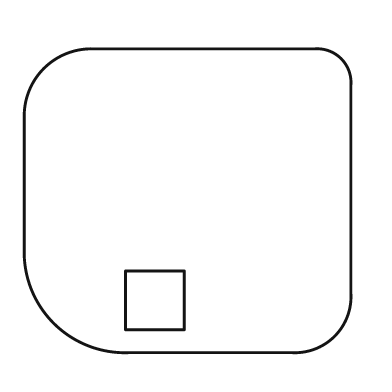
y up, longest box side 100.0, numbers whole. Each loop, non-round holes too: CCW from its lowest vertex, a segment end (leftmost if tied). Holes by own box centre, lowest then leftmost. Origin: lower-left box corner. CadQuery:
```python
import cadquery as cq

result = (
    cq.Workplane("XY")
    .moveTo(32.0, 0.0)
    .lineTo(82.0, 0.0)
    .threePointArc((95.0, 5.0), (100.0, 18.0))
    .lineTo(100.0, 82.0)
    .threePointArc((97.0, 90.0), (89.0, 93.0))
    .lineTo(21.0, 93.0)
    .threePointArc((6.0, 87.0), (0.0, 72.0))
    .lineTo(0.0, 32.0)
    .threePointArc((9.0, 9.0), (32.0, 0.0))
    .close()
    .moveTo(31.0, 7.0)
    .lineTo(49.0, 7.0)
    .lineTo(49.0, 25.0)
    .lineTo(31.0, 25.0)
    .close()
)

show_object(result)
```